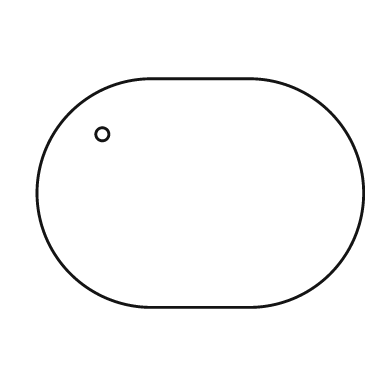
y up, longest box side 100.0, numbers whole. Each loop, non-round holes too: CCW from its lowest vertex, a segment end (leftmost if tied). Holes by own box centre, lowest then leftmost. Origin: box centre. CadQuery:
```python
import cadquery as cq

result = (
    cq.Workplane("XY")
    .moveTo(-15.0, -35.0)
    .lineTo(15.0, -35.0)
    .threePointArc((50.0, 0.0), (15.0, 35.0))
    .lineTo(-15.0, 35.0)
    .threePointArc((-50.0, 0.0), (-15.0, -35.0))
    .close()
    .moveTo(-30.0, 18.0)
    .circle(2.0)
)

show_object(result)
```